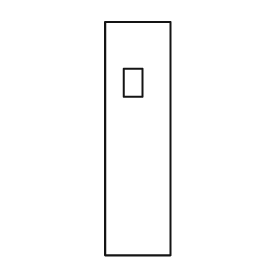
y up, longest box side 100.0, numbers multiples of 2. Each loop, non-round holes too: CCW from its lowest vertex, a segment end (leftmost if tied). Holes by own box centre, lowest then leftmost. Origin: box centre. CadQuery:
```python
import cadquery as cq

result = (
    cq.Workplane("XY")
    .moveTo(-14.0, -50.0)
    .lineTo(14.0, -50.0)
    .lineTo(14.0, 50.0)
    .lineTo(-14.0, 50.0)
    .close()
    .moveTo(-6.0, 18.0)
    .lineTo(2.0, 18.0)
    .lineTo(2.0, 30.0)
    .lineTo(-6.0, 30.0)
    .close()
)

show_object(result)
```